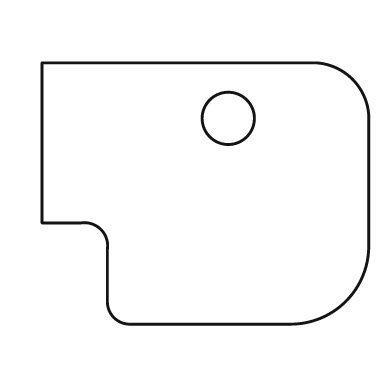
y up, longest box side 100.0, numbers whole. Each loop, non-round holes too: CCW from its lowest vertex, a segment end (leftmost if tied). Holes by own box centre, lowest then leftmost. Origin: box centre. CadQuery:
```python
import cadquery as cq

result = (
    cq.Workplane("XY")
    .moveTo(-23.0, -40.0)
    .lineTo(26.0, -40.0)
    .threePointArc((43.0, -33.0), (50.0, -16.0))
    .lineTo(50.0, 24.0)
    .threePointArc((45.0, 35.0), (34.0, 40.0))
    .lineTo(-50.0, 40.0)
    .lineTo(-50.0, -9.0)
    .lineTo(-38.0, -9.0)
    .threePointArc((-32.0, -11.0), (-30.0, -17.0))
    .lineTo(-30.0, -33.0)
    .threePointArc((-28.0, -38.0), (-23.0, -40.0))
    .close()
    .moveTo(7.0, 23.0)
    .circle(8.0)
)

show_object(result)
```